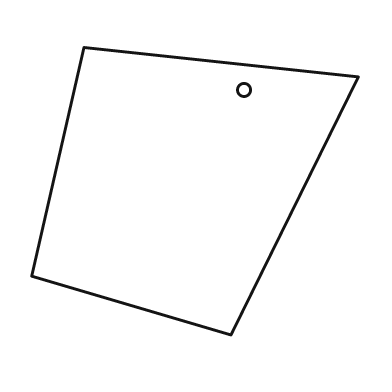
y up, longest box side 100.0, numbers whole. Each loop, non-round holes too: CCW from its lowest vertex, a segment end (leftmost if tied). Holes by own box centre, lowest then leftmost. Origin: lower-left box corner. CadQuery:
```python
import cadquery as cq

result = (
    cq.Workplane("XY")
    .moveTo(61.0, 0.0)
    .lineTo(100.0, 79.0)
    .lineTo(16.0, 88.0)
    .lineTo(0.0, 18.0)
    .close()
    .moveTo(65.0, 75.0)
    .circle(2.0)
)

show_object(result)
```